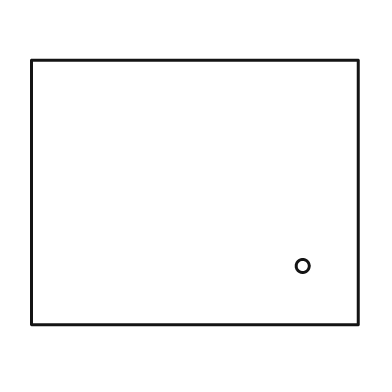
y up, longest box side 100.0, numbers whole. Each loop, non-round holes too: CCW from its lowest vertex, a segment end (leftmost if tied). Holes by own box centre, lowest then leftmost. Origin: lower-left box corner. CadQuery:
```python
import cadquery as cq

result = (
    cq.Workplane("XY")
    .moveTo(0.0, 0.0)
    .lineTo(100.0, 0.0)
    .lineTo(100.0, 81.0)
    .lineTo(0.0, 81.0)
    .close()
    .moveTo(83.0, 18.0)
    .circle(2.0)
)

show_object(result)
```